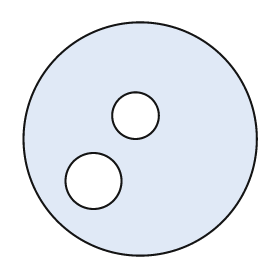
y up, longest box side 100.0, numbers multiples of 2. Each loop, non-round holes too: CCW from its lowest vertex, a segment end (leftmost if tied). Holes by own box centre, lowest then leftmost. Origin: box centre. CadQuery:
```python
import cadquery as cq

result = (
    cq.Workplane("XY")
    .moveTo(0.0, 0.0)
    .circle(50.0)
    .moveTo(-20.0, -18.0)
    .circle(12.0)
    .moveTo(-2.0, 10.0)
    .circle(10.0)
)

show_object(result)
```